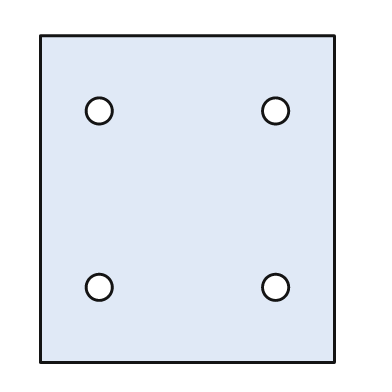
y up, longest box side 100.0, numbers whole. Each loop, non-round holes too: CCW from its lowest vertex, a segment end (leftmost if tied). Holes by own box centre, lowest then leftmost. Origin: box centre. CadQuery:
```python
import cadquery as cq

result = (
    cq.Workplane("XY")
    .moveTo(-45.0, -50.0)
    .lineTo(45.0, -50.0)
    .lineTo(45.0, 50.0)
    .lineTo(-45.0, 50.0)
    .close()
    .moveTo(-27.0, -27.0)
    .circle(4.0)
    .moveTo(27.0, -27.0)
    .circle(4.0)
    .moveTo(-27.0, 27.0)
    .circle(4.0)
    .moveTo(27.0, 27.0)
    .circle(4.0)
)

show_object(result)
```